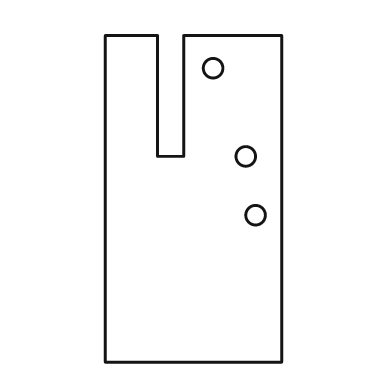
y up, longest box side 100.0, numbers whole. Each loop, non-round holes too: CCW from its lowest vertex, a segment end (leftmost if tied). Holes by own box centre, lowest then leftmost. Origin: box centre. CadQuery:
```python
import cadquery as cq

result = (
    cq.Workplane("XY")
    .moveTo(-27.0, -50.0)
    .lineTo(27.0, -50.0)
    .lineTo(27.0, 50.0)
    .lineTo(-3.0, 50.0)
    .lineTo(-3.0, 13.0)
    .lineTo(-11.0, 13.0)
    .lineTo(-11.0, 50.0)
    .lineTo(-27.0, 50.0)
    .close()
    .moveTo(19.0, -5.0)
    .circle(3.0)
    .moveTo(16.0, 13.0)
    .circle(3.0)
    .moveTo(6.0, 40.0)
    .circle(3.0)
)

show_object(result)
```